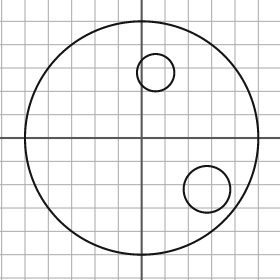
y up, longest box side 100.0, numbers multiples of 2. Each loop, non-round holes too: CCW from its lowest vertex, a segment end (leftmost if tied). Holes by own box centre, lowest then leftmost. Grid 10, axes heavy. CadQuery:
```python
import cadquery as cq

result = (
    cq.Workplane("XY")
    .moveTo(0.0, 0.0)
    .circle(50.0)
    .moveTo(28.0, -22.0)
    .circle(10.0)
    .moveTo(6.0, 28.0)
    .circle(8.0)
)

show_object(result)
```